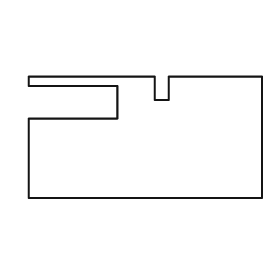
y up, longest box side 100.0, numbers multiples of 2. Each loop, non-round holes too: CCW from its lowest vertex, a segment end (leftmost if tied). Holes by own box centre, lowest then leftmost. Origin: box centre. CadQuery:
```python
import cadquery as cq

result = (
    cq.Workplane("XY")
    .moveTo(-50.0, -26.0)
    .lineTo(50.0, -26.0)
    .lineTo(50.0, 26.0)
    .lineTo(10.0, 26.0)
    .lineTo(10.0, 16.0)
    .lineTo(4.0, 16.0)
    .lineTo(4.0, 26.0)
    .lineTo(-50.0, 26.0)
    .lineTo(-50.0, 22.0)
    .lineTo(-12.0, 22.0)
    .lineTo(-12.0, 8.0)
    .lineTo(-50.0, 8.0)
    .close()
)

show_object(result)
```